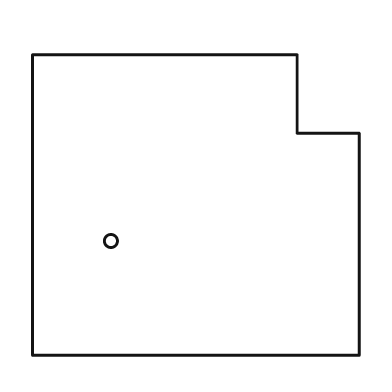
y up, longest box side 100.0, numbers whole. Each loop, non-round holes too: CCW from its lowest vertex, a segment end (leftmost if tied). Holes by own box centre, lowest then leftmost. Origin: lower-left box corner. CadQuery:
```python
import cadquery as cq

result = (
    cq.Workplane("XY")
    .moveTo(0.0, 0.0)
    .lineTo(100.0, 0.0)
    .lineTo(100.0, 68.0)
    .lineTo(81.0, 68.0)
    .lineTo(81.0, 92.0)
    .lineTo(0.0, 92.0)
    .close()
    .moveTo(24.0, 35.0)
    .circle(2.0)
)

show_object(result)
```